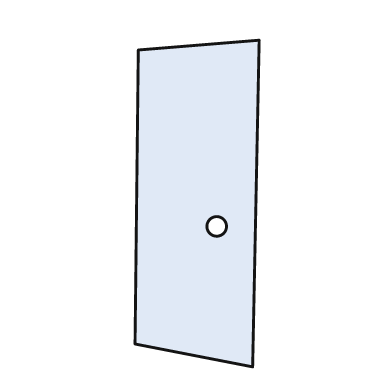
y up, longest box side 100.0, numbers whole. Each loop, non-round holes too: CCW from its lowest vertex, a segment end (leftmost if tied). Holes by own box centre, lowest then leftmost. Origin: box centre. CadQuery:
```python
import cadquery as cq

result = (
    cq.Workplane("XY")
    .moveTo(17.0, -50.0)
    .lineTo(19.0, 50.0)
    .lineTo(-18.0, 47.0)
    .lineTo(-19.0, -43.0)
    .close()
    .moveTo(6.0, -7.0)
    .circle(3.0)
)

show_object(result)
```